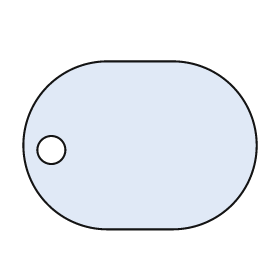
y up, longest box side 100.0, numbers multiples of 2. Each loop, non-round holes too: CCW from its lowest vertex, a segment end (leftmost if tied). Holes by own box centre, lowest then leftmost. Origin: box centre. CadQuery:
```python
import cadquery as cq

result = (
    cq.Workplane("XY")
    .moveTo(-14.0, -36.0)
    .lineTo(14.0, -36.0)
    .threePointArc((50.0, 0.0), (14.0, 36.0))
    .lineTo(-14.0, 36.0)
    .threePointArc((-50.0, 0.0), (-14.0, -36.0))
    .close()
    .moveTo(-38.0, -2.0)
    .circle(6.0)
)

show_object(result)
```